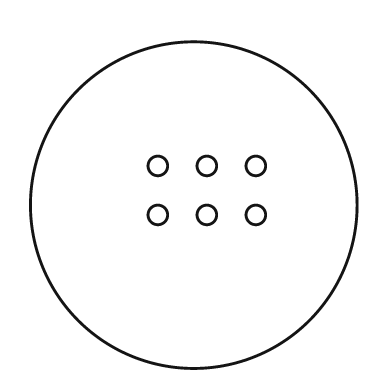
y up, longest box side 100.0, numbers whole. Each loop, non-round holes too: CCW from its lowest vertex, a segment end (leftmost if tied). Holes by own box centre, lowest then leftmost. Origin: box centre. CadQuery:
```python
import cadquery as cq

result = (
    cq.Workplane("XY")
    .moveTo(0.0, 0.0)
    .circle(50.0)
    .moveTo(-11.0, -3.0)
    .circle(3.0)
    .moveTo(4.0, -3.0)
    .circle(3.0)
    .moveTo(19.0, -3.0)
    .circle(3.0)
    .moveTo(-11.0, 12.0)
    .circle(3.0)
    .moveTo(4.0, 12.0)
    .circle(3.0)
    .moveTo(19.0, 12.0)
    .circle(3.0)
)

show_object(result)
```